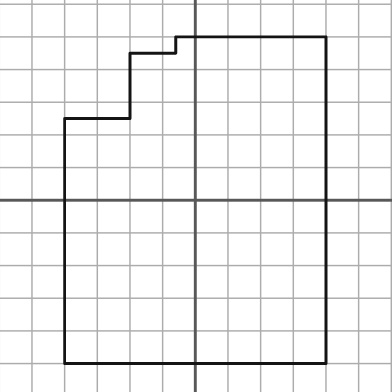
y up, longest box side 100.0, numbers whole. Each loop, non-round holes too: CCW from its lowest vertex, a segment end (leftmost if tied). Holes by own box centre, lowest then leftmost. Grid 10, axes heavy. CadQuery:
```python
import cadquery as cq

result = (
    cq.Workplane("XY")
    .moveTo(-40.0, -50.0)
    .lineTo(40.0, -50.0)
    .lineTo(40.0, 50.0)
    .lineTo(-6.0, 50.0)
    .lineTo(-6.0, 45.0)
    .lineTo(-20.0, 45.0)
    .lineTo(-20.0, 25.0)
    .lineTo(-40.0, 25.0)
    .close()
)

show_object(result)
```